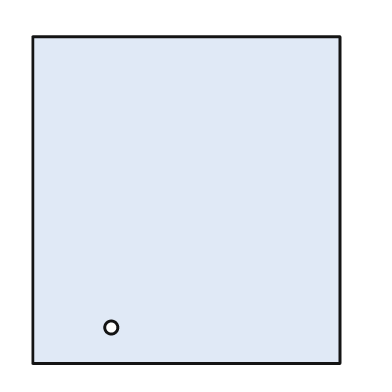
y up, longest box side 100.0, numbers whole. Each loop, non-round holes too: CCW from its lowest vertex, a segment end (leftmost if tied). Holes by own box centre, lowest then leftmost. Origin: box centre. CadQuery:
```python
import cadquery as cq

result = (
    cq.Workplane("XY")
    .moveTo(-47.0, -50.0)
    .lineTo(47.0, -50.0)
    .lineTo(47.0, 50.0)
    .lineTo(-47.0, 50.0)
    .close()
    .moveTo(-23.0, -39.0)
    .circle(2.0)
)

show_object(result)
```